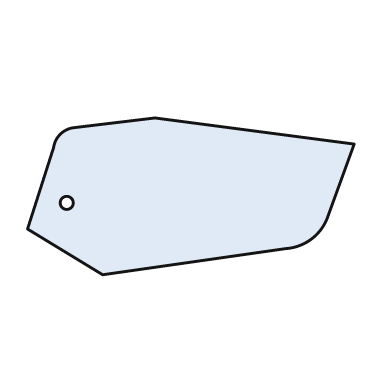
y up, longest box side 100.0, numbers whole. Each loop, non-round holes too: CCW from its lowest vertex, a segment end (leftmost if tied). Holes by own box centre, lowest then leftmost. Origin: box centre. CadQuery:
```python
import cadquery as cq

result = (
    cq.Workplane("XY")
    .moveTo(-27.0, -24.0)
    .lineTo(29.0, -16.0)
    .threePointArc((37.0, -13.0), (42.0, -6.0))
    .lineTo(50.0, 16.0)
    .lineTo(-11.0, 24.0)
    .lineTo(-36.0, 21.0)
    .threePointArc((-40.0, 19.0), (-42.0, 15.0))
    .lineTo(-50.0, -10.0)
    .close()
    .moveTo(-38.0, -2.0)
    .circle(2.0)
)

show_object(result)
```